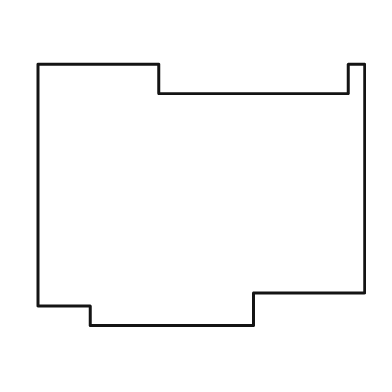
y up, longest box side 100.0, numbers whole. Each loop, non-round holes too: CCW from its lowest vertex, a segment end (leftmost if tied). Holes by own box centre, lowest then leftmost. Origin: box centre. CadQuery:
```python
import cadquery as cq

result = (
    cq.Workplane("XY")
    .moveTo(-34.0, -40.0)
    .lineTo(16.0, -40.0)
    .lineTo(16.0, -30.0)
    .lineTo(50.0, -30.0)
    .lineTo(50.0, 40.0)
    .lineTo(45.0, 40.0)
    .lineTo(45.0, 31.0)
    .lineTo(-13.0, 31.0)
    .lineTo(-13.0, 40.0)
    .lineTo(-50.0, 40.0)
    .lineTo(-50.0, -34.0)
    .lineTo(-34.0, -34.0)
    .close()
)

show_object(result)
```